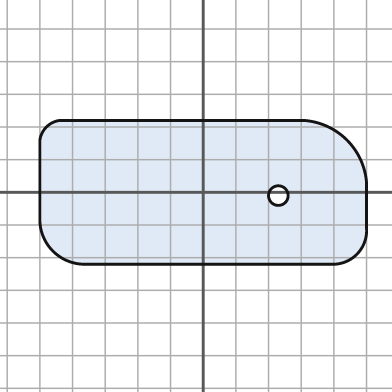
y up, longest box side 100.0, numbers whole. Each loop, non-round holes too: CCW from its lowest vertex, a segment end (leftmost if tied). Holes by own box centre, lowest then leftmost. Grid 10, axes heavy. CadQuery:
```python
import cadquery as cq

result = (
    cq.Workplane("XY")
    .moveTo(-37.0, -22.0)
    .lineTo(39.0, -22.0)
    .threePointArc((47.0, -19.0), (50.0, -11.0))
    .lineTo(50.0, 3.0)
    .threePointArc((44.0, 16.0), (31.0, 22.0))
    .lineTo(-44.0, 22.0)
    .threePointArc((-48.0, 20.0), (-50.0, 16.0))
    .lineTo(-50.0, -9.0)
    .threePointArc((-46.0, -18.0), (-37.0, -22.0))
    .close()
    .moveTo(23.0, -1.0)
    .circle(3.0)
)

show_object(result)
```